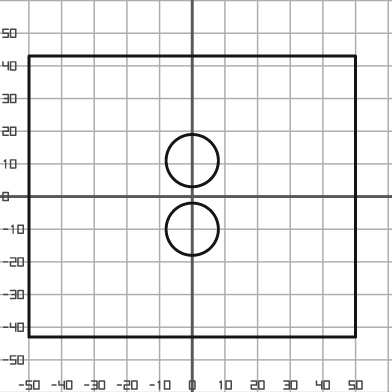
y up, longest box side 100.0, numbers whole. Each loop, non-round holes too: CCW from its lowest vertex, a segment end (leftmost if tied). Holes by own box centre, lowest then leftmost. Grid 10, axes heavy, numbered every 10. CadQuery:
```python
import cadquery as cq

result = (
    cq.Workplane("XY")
    .moveTo(-50.0, -43.0)
    .lineTo(50.0, -43.0)
    .lineTo(50.0, 43.0)
    .lineTo(-50.0, 43.0)
    .close()
    .moveTo(0.0, -10.0)
    .circle(8.0)
    .moveTo(0.0, 11.0)
    .circle(8.0)
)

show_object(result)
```